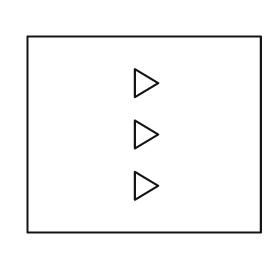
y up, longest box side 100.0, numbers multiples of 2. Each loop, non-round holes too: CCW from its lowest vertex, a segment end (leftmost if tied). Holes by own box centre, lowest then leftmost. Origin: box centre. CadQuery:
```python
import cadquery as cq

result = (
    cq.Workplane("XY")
    .moveTo(-50.0, -42.0)
    .lineTo(50.0, -42.0)
    .lineTo(50.0, 42.0)
    .lineTo(-50.0, 42.0)
    .close()
    .moveTo(-4.0, -28.0)
    .lineTo(6.0, -22.0)
    .lineTo(-4.0, -16.0)
    .close()
    .moveTo(-4.0, -6.0)
    .lineTo(6.0, 0.0)
    .lineTo(-4.0, 6.0)
    .close()
    .moveTo(-4.0, 16.0)
    .lineTo(6.0, 22.0)
    .lineTo(-4.0, 28.0)
    .close()
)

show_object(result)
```